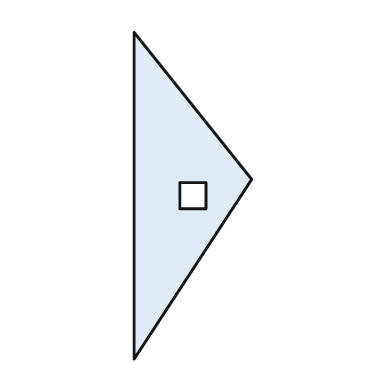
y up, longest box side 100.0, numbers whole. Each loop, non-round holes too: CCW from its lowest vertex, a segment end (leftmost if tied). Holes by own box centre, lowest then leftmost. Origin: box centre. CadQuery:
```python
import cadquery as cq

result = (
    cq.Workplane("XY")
    .moveTo(-18.0, -50.0)
    .lineTo(18.0, 5.0)
    .lineTo(-18.0, 50.0)
    .close()
    .moveTo(-4.0, -4.0)
    .lineTo(4.0, -4.0)
    .lineTo(4.0, 4.0)
    .lineTo(-4.0, 4.0)
    .close()
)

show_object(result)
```